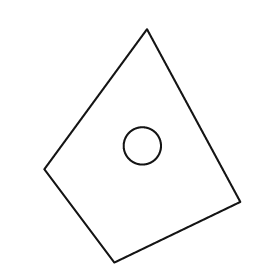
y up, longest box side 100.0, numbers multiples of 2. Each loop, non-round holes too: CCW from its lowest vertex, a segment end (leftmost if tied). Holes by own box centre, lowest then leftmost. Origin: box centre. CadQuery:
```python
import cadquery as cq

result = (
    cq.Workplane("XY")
    .moveTo(-12.0, -50.0)
    .lineTo(42.0, -24.0)
    .lineTo(2.0, 50.0)
    .lineTo(-42.0, -10.0)
    .close()
    .moveTo(0.0, 0.0)
    .circle(8.0)
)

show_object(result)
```